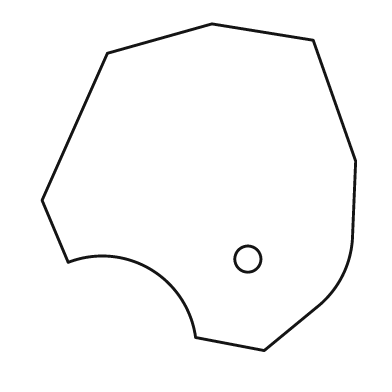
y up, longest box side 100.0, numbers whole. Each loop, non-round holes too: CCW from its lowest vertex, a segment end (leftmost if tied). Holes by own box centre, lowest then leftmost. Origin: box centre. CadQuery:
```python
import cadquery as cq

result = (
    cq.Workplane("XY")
    .moveTo(20.0, -50.0)
    .lineTo(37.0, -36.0)
    .threePointArc((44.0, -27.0), (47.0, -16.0))
    .lineTo(48.0, 8.0)
    .lineTo(35.0, 45.0)
    .lineTo(4.0, 50.0)
    .lineTo(-28.0, 41.0)
    .lineTo(-48.0, -4.0)
    .lineTo(-40.0, -23.0)
    .threePointArc((-15.0, -25.0), (-1.0, -46.0))
    .close()
    .moveTo(15.0, -22.0)
    .circle(4.0)
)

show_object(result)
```